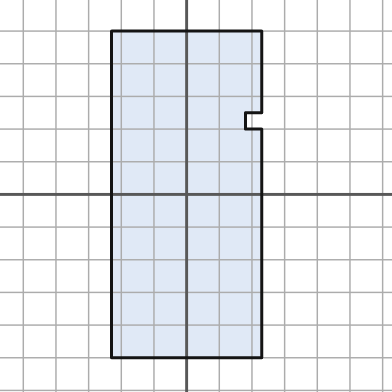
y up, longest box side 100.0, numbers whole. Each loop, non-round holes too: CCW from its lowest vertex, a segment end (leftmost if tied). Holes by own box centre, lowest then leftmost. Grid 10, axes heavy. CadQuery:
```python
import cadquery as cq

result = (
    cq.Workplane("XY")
    .moveTo(-23.0, -50.0)
    .lineTo(23.0, -50.0)
    .lineTo(23.0, 20.0)
    .lineTo(18.0, 20.0)
    .lineTo(18.0, 25.0)
    .lineTo(23.0, 25.0)
    .lineTo(23.0, 50.0)
    .lineTo(-23.0, 50.0)
    .close()
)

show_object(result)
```